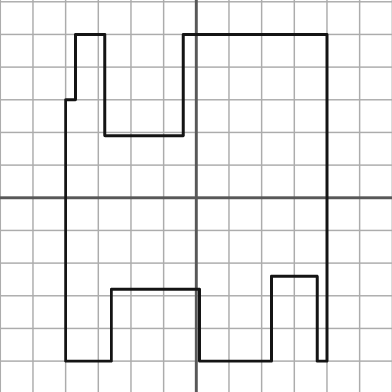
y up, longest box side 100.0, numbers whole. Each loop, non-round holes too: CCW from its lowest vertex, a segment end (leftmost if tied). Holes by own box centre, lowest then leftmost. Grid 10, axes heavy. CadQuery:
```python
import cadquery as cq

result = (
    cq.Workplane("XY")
    .moveTo(-40.0, -50.0)
    .lineTo(-26.0, -50.0)
    .lineTo(-26.0, -28.0)
    .lineTo(1.0, -28.0)
    .lineTo(1.0, -50.0)
    .lineTo(23.0, -50.0)
    .lineTo(23.0, -24.0)
    .lineTo(37.0, -24.0)
    .lineTo(37.0, -50.0)
    .lineTo(40.0, -50.0)
    .lineTo(40.0, 50.0)
    .lineTo(-4.0, 50.0)
    .lineTo(-4.0, 19.0)
    .lineTo(-28.0, 19.0)
    .lineTo(-28.0, 50.0)
    .lineTo(-37.0, 50.0)
    .lineTo(-37.0, 30.0)
    .lineTo(-40.0, 30.0)
    .close()
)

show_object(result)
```